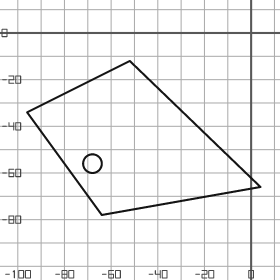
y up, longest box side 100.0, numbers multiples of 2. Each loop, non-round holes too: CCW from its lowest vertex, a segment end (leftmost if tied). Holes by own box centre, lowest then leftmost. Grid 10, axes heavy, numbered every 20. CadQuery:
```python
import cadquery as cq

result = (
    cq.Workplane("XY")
    .moveTo(-64.0, -78.0)
    .lineTo(4.0, -66.0)
    .lineTo(-52.0, -12.0)
    .lineTo(-96.0, -34.0)
    .close()
    .moveTo(-68.0, -56.0)
    .circle(4.0)
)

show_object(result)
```